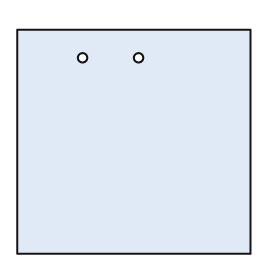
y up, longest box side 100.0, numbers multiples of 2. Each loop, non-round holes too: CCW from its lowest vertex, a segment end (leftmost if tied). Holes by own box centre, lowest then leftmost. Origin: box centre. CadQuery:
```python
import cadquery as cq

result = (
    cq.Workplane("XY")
    .moveTo(-50.0, -48.0)
    .lineTo(50.0, -48.0)
    .lineTo(50.0, 48.0)
    .lineTo(-50.0, 48.0)
    .close()
    .moveTo(-22.0, 36.0)
    .circle(2.0)
    .moveTo(2.0, 36.0)
    .circle(2.0)
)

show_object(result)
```